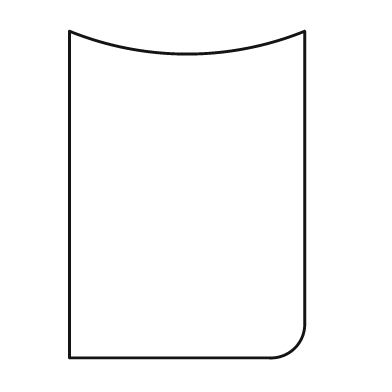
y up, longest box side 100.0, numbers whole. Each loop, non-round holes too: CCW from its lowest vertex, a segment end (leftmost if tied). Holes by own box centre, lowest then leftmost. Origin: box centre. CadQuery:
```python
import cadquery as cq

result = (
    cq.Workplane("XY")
    .moveTo(-36.0, -50.0)
    .lineTo(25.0, -50.0)
    .threePointArc((33.0, -47.0), (36.0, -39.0))
    .lineTo(36.0, 50.0)
    .threePointArc((0.0, 43.0), (-36.0, 50.0))
    .close()
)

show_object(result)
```